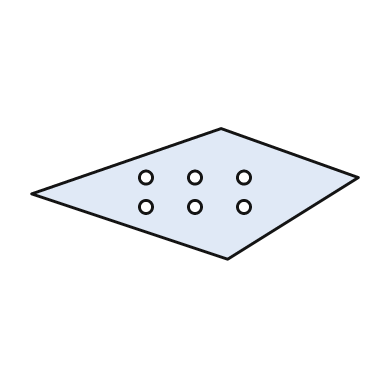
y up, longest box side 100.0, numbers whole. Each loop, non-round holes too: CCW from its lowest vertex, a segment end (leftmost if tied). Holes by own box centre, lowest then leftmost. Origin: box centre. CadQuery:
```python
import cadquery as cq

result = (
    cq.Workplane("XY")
    .moveTo(10.0, -20.0)
    .lineTo(50.0, 5.0)
    .lineTo(8.0, 20.0)
    .lineTo(-50.0, 0.0)
    .close()
    .moveTo(-15.0, -4.0)
    .circle(2.0)
    .moveTo(0.0, -4.0)
    .circle(2.0)
    .moveTo(15.0, -4.0)
    .circle(2.0)
    .moveTo(-15.0, 5.0)
    .circle(2.0)
    .moveTo(0.0, 5.0)
    .circle(2.0)
    .moveTo(15.0, 5.0)
    .circle(2.0)
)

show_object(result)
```